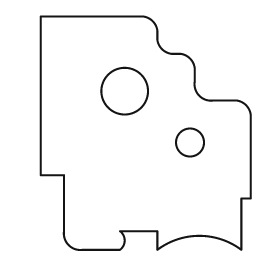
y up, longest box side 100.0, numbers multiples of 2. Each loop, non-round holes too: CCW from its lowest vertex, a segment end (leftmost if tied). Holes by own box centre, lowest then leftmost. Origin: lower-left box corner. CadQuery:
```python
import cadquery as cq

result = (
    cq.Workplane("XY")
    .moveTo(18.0, 0.0)
    .lineTo(34.0, 0.0)
    .threePointArc((36.0, 4.0), (34.0, 8.0))
    .lineTo(50.0, 8.0)
    .lineTo(50.0, 0.0)
    .threePointArc((68.0, 6.0), (86.0, 0.0))
    .lineTo(86.0, 22.0)
    .lineTo(90.0, 22.0)
    .lineTo(90.0, 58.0)
    .threePointArc((88.0, 62.0), (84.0, 64.0))
    .lineTo(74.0, 64.0)
    .threePointArc((68.0, 66.0), (66.0, 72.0))
    .lineTo(66.0, 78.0)
    .threePointArc((64.0, 82.0), (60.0, 84.0))
    .lineTo(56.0, 84.0)
    .threePointArc((52.0, 86.0), (50.0, 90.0))
    .lineTo(50.0, 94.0)
    .threePointArc((48.0, 98.0), (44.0, 100.0))
    .lineTo(0.0, 100.0)
    .lineTo(0.0, 32.0)
    .lineTo(10.0, 32.0)
    .lineTo(10.0, 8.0)
    .threePointArc((12.0, 2.0), (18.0, 0.0))
    .close()
    .moveTo(64.0, 46.0)
    .circle(6.0)
    .moveTo(36.0, 68.0)
    .circle(10.0)
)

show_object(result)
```